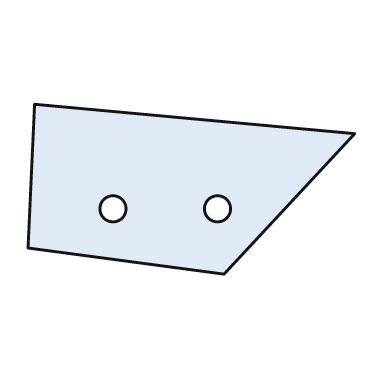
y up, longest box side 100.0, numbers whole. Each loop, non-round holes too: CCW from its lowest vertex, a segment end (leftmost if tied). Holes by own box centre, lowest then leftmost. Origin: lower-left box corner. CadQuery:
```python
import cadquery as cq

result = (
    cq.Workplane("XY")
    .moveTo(60.0, 0.0)
    .lineTo(100.0, 43.0)
    .lineTo(2.0, 52.0)
    .lineTo(0.0, 8.0)
    .close()
    .moveTo(26.0, 20.0)
    .circle(4.0)
    .moveTo(58.0, 20.0)
    .circle(4.0)
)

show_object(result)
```